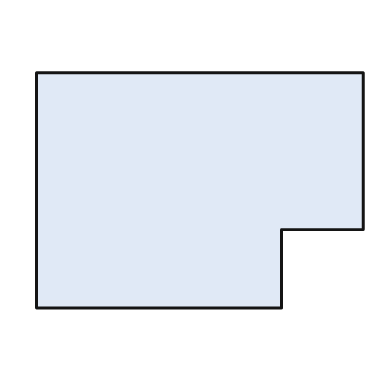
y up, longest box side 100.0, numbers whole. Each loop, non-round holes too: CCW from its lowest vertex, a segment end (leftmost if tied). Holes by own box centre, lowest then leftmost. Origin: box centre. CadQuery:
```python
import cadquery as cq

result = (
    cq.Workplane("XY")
    .moveTo(-50.0, -36.0)
    .lineTo(25.0, -36.0)
    .lineTo(25.0, -12.0)
    .lineTo(50.0, -12.0)
    .lineTo(50.0, 36.0)
    .lineTo(-50.0, 36.0)
    .close()
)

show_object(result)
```